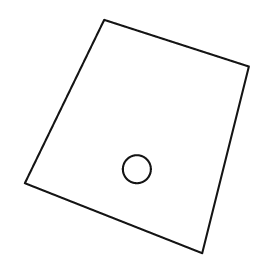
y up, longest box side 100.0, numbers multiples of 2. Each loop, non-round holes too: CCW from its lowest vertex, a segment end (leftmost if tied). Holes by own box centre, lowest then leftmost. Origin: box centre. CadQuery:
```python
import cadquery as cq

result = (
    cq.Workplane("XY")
    .moveTo(28.0, -50.0)
    .lineTo(48.0, 30.0)
    .lineTo(-14.0, 50.0)
    .lineTo(-48.0, -20.0)
    .close()
    .moveTo(0.0, -14.0)
    .circle(6.0)
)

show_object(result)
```